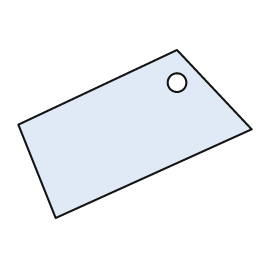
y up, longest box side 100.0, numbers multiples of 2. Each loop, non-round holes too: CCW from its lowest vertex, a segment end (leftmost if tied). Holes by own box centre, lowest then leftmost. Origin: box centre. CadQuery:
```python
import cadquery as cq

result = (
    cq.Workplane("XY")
    .moveTo(-34.0, -36.0)
    .lineTo(50.0, 2.0)
    .lineTo(18.0, 36.0)
    .lineTo(-50.0, 4.0)
    .close()
    .moveTo(18.0, 22.0)
    .circle(4.0)
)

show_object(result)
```